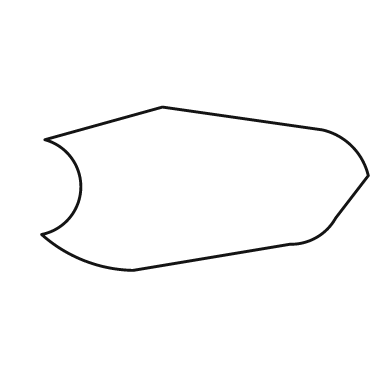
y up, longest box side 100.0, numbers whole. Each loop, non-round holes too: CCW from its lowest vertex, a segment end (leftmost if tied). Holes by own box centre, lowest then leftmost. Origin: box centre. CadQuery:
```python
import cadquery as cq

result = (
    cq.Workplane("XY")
    .moveTo(-22.0, -25.0)
    .lineTo(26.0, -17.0)
    .threePointArc((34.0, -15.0), (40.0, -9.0))
    .lineTo(50.0, 4.0)
    .threePointArc((45.0, 13.0), (36.0, 18.0))
    .lineTo(-13.0, 25.0)
    .lineTo(-49.0, 15.0)
    .threePointArc((-38.0, 0.0), (-50.0, -14.0))
    .threePointArc((-37.0, -22.0), (-22.0, -25.0))
    .close()
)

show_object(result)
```